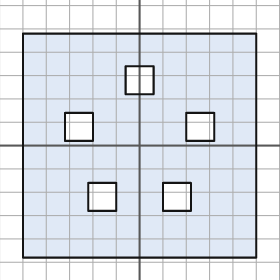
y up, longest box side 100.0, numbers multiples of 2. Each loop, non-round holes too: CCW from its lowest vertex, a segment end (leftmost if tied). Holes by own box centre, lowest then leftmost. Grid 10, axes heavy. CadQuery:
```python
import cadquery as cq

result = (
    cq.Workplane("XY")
    .moveTo(-50.0, -48.0)
    .lineTo(50.0, -48.0)
    .lineTo(50.0, 48.0)
    .lineTo(-50.0, 48.0)
    .close()
    .moveTo(-22.0, -28.0)
    .lineTo(-10.0, -28.0)
    .lineTo(-10.0, -16.0)
    .lineTo(-22.0, -16.0)
    .close()
    .moveTo(10.0, -28.0)
    .lineTo(22.0, -28.0)
    .lineTo(22.0, -16.0)
    .lineTo(10.0, -16.0)
    .close()
    .moveTo(-32.0, 2.0)
    .lineTo(-20.0, 2.0)
    .lineTo(-20.0, 14.0)
    .lineTo(-32.0, 14.0)
    .close()
    .moveTo(20.0, 2.0)
    .lineTo(32.0, 2.0)
    .lineTo(32.0, 14.0)
    .lineTo(20.0, 14.0)
    .close()
    .moveTo(-6.0, 22.0)
    .lineTo(6.0, 22.0)
    .lineTo(6.0, 34.0)
    .lineTo(-6.0, 34.0)
    .close()
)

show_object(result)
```